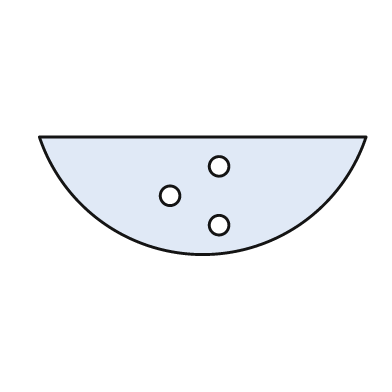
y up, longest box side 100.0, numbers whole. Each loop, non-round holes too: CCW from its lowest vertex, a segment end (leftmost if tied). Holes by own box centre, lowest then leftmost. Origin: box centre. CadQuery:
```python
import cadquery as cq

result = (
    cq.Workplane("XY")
    .moveTo(-50.0, 18.0)
    .threePointArc((0.0, -18.0), (50.0, 18.0))
    .close()
    .moveTo(5.0, -9.0)
    .circle(3.0)
    .moveTo(-10.0, 0.0)
    .circle(3.0)
    .moveTo(5.0, 9.0)
    .circle(3.0)
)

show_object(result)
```